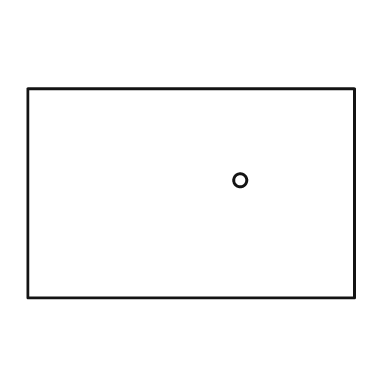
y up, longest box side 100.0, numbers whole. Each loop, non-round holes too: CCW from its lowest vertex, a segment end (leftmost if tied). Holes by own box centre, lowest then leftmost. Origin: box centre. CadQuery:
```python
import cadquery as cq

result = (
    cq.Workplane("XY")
    .moveTo(-50.0, -32.0)
    .lineTo(50.0, -32.0)
    .lineTo(50.0, 32.0)
    .lineTo(-50.0, 32.0)
    .close()
    .moveTo(15.0, 4.0)
    .circle(2.0)
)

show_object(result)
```